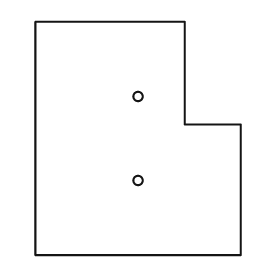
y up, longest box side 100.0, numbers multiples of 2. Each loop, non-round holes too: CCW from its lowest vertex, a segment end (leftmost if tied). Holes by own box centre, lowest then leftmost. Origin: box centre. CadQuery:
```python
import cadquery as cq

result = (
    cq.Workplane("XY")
    .moveTo(-44.0, -50.0)
    .lineTo(44.0, -50.0)
    .lineTo(44.0, 6.0)
    .lineTo(20.0, 6.0)
    .lineTo(20.0, 50.0)
    .lineTo(-44.0, 50.0)
    .close()
    .moveTo(0.0, -18.0)
    .circle(2.0)
    .moveTo(0.0, 18.0)
    .circle(2.0)
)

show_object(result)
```